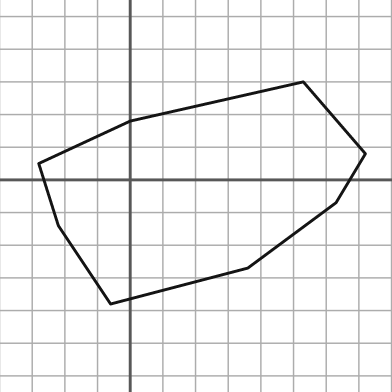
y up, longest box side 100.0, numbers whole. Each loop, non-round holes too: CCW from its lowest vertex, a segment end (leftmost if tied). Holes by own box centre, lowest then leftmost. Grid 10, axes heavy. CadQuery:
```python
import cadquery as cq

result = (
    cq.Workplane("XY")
    .moveTo(-6.0, -38.0)
    .lineTo(36.0, -27.0)
    .lineTo(63.0, -7.0)
    .lineTo(72.0, 8.0)
    .lineTo(53.0, 30.0)
    .lineTo(0.0, 18.0)
    .lineTo(-28.0, 5.0)
    .lineTo(-22.0, -14.0)
    .close()
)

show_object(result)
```